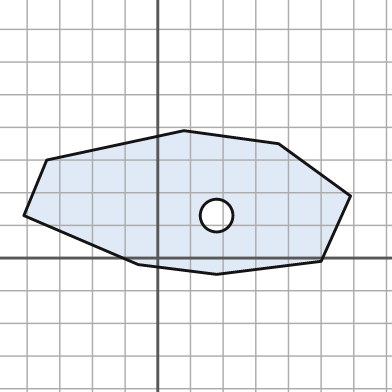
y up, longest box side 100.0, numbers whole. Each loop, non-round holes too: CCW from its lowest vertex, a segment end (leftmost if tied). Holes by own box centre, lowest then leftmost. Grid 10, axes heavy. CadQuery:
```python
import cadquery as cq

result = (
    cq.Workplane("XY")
    .moveTo(18.0, -5.0)
    .lineTo(50.0, -1.0)
    .lineTo(59.0, 19.0)
    .lineTo(37.0, 35.0)
    .lineTo(8.0, 39.0)
    .lineTo(-34.0, 30.0)
    .lineTo(-41.0, 13.0)
    .lineTo(-6.0, -2.0)
    .close()
    .moveTo(18.0, 13.0)
    .circle(5.0)
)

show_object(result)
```